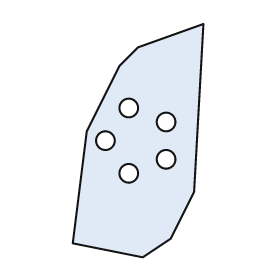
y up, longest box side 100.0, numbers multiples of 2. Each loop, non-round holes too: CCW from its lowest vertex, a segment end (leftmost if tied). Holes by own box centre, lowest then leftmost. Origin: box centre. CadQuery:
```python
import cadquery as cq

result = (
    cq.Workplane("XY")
    .moveTo(2.0, -50.0)
    .lineTo(14.0, -42.0)
    .lineTo(24.0, -22.0)
    .lineTo(28.0, 50.0)
    .lineTo(0.0, 40.0)
    .lineTo(-8.0, 32.0)
    .lineTo(-22.0, 4.0)
    .lineTo(-28.0, -44.0)
    .close()
    .moveTo(-4.0, -14.0)
    .circle(4.0)
    .moveTo(12.0, -8.0)
    .circle(4.0)
    .moveTo(-14.0, 0.0)
    .circle(4.0)
    .moveTo(12.0, 8.0)
    .circle(4.0)
    .moveTo(-4.0, 14.0)
    .circle(4.0)
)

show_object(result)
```